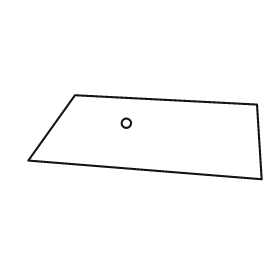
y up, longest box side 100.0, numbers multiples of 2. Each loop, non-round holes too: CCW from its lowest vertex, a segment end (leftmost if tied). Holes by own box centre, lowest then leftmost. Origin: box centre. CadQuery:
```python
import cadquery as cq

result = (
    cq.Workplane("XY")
    .moveTo(50.0, -18.0)
    .lineTo(48.0, 14.0)
    .lineTo(-30.0, 18.0)
    .lineTo(-50.0, -10.0)
    .close()
    .moveTo(-8.0, 6.0)
    .circle(2.0)
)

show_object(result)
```